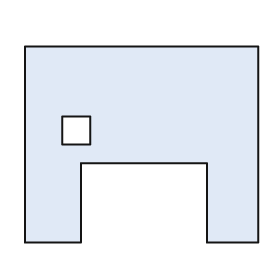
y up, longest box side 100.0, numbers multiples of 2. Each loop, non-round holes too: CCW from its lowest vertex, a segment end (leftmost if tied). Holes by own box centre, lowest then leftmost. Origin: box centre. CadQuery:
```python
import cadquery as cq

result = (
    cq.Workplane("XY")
    .moveTo(-50.0, -42.0)
    .lineTo(-26.0, -42.0)
    .lineTo(-26.0, -8.0)
    .lineTo(28.0, -8.0)
    .lineTo(28.0, -42.0)
    .lineTo(50.0, -42.0)
    .lineTo(50.0, 42.0)
    .lineTo(-50.0, 42.0)
    .close()
    .moveTo(-34.0, 0.0)
    .lineTo(-22.0, 0.0)
    .lineTo(-22.0, 12.0)
    .lineTo(-34.0, 12.0)
    .close()
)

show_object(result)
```